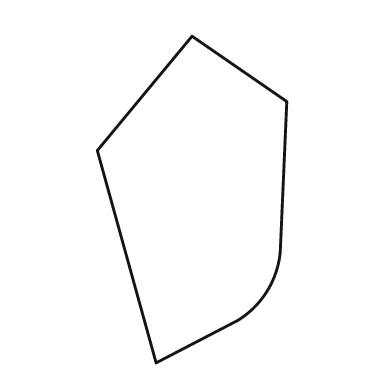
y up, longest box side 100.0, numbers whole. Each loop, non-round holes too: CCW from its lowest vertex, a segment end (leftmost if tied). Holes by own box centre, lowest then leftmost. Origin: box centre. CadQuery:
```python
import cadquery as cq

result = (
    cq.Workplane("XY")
    .moveTo(-11.0, -50.0)
    .lineTo(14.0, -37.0)
    .threePointArc((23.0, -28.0), (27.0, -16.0))
    .lineTo(29.0, 30.0)
    .lineTo(0.0, 50.0)
    .lineTo(-29.0, 15.0)
    .close()
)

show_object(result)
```